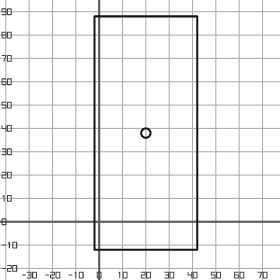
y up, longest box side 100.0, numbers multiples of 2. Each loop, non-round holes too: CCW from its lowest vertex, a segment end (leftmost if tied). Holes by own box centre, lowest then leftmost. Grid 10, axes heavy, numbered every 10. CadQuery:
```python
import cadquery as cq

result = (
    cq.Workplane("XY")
    .moveTo(-2.0, -12.0)
    .lineTo(42.0, -12.0)
    .lineTo(42.0, 88.0)
    .lineTo(-2.0, 88.0)
    .close()
    .moveTo(20.0, 38.0)
    .circle(2.0)
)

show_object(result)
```